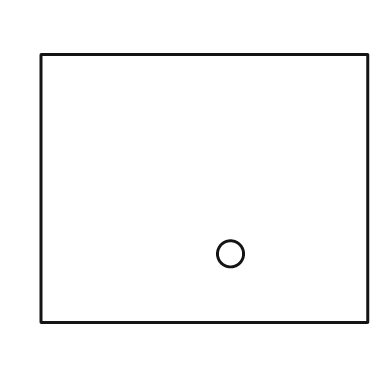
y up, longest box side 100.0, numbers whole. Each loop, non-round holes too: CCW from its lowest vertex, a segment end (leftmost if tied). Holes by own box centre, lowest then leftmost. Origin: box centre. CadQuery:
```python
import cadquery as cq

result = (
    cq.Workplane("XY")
    .moveTo(-50.0, -41.0)
    .lineTo(50.0, -41.0)
    .lineTo(50.0, 41.0)
    .lineTo(-50.0, 41.0)
    .close()
    .moveTo(8.0, -20.0)
    .circle(4.0)
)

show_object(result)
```